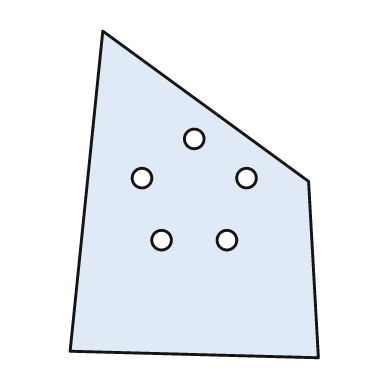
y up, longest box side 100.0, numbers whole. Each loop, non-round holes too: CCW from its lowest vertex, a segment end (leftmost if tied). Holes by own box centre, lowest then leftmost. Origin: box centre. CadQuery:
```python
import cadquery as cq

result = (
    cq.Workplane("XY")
    .moveTo(38.0, -50.0)
    .lineTo(35.0, 4.0)
    .lineTo(-28.0, 50.0)
    .lineTo(-38.0, -48.0)
    .close()
    .moveTo(-10.0, -14.0)
    .circle(3.0)
    .moveTo(10.0, -14.0)
    .circle(3.0)
    .moveTo(-16.0, 5.0)
    .circle(3.0)
    .moveTo(16.0, 5.0)
    .circle(3.0)
    .moveTo(0.0, 17.0)
    .circle(3.0)
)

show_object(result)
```